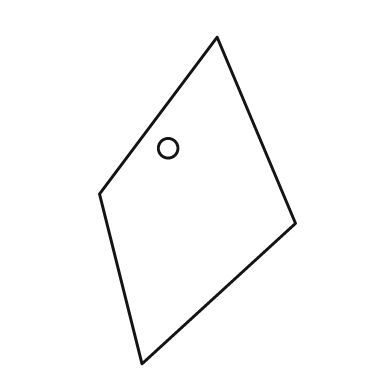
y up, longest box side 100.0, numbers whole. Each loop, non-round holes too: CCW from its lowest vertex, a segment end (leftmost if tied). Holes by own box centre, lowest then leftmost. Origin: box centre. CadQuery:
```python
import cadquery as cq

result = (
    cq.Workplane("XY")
    .moveTo(-17.0, -50.0)
    .lineTo(30.0, -7.0)
    .lineTo(6.0, 50.0)
    .lineTo(-30.0, 2.0)
    .close()
    .moveTo(-9.0, 16.0)
    .circle(3.0)
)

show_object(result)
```